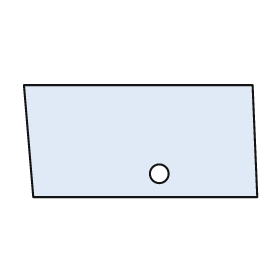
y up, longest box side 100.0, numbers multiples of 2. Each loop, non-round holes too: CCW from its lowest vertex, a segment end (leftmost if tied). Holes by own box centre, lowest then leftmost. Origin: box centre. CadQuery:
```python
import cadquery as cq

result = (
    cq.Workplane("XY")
    .moveTo(-46.0, -24.0)
    .lineTo(50.0, -24.0)
    .lineTo(48.0, 24.0)
    .lineTo(-50.0, 24.0)
    .close()
    .moveTo(8.0, -14.0)
    .circle(4.0)
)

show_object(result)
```